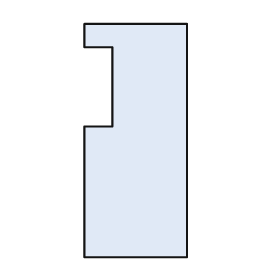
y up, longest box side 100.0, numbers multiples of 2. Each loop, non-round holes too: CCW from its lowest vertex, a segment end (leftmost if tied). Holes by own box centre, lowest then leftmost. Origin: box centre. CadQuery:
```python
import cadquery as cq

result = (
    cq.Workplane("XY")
    .moveTo(-22.0, -50.0)
    .lineTo(22.0, -50.0)
    .lineTo(22.0, 50.0)
    .lineTo(-22.0, 50.0)
    .lineTo(-22.0, 40.0)
    .lineTo(-10.0, 40.0)
    .lineTo(-10.0, 6.0)
    .lineTo(-22.0, 6.0)
    .close()
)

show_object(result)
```